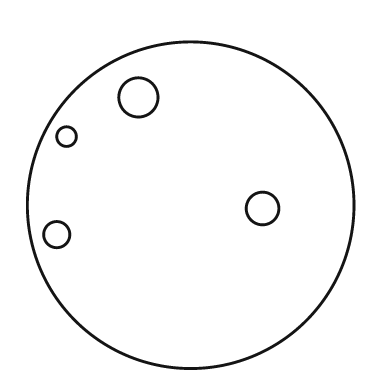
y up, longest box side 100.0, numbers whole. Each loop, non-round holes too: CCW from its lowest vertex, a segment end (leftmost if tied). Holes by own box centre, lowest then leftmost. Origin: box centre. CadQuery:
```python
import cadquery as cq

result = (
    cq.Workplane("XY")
    .moveTo(0.0, 0.0)
    .circle(50.0)
    .moveTo(-41.0, -9.0)
    .circle(4.0)
    .moveTo(22.0, -1.0)
    .circle(5.0)
    .moveTo(-38.0, 21.0)
    .circle(3.0)
    .moveTo(-16.0, 33.0)
    .circle(6.0)
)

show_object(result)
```